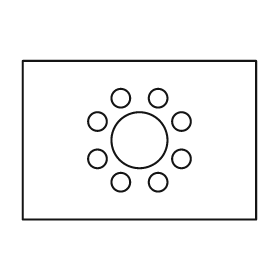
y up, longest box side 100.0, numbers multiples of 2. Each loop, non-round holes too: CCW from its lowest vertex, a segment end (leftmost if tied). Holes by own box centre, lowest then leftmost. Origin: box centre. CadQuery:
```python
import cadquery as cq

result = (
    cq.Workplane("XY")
    .moveTo(-50.0, -34.0)
    .lineTo(50.0, -34.0)
    .lineTo(50.0, 34.0)
    .lineTo(-50.0, 34.0)
    .close()
    .moveTo(-8.0, -18.0)
    .circle(4.0)
    .moveTo(8.0, -18.0)
    .circle(4.0)
    .moveTo(-18.0, -8.0)
    .circle(4.0)
    .moveTo(18.0, -8.0)
    .circle(4.0)
    .moveTo(0.0, 0.0)
    .circle(12.0)
    .moveTo(-18.0, 8.0)
    .circle(4.0)
    .moveTo(18.0, 8.0)
    .circle(4.0)
    .moveTo(-8.0, 18.0)
    .circle(4.0)
    .moveTo(8.0, 18.0)
    .circle(4.0)
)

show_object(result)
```